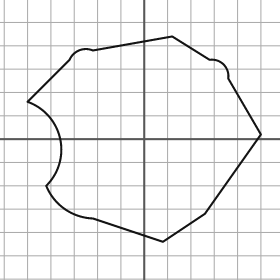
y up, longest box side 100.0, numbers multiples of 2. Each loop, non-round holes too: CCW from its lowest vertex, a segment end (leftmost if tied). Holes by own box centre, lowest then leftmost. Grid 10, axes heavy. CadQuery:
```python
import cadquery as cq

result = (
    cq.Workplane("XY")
    .moveTo(8.0, -44.0)
    .lineTo(26.0, -32.0)
    .lineTo(50.0, 2.0)
    .lineTo(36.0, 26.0)
    .threePointArc((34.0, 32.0), (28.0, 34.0))
    .lineTo(12.0, 44.0)
    .lineTo(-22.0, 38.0)
    .threePointArc((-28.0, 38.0), (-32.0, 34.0))
    .lineTo(-50.0, 16.0)
    .threePointArc((-36.0, 0.0), (-42.0, -20.0))
    .threePointArc((-34.0, -30.0), (-22.0, -34.0))
    .close()
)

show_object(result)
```